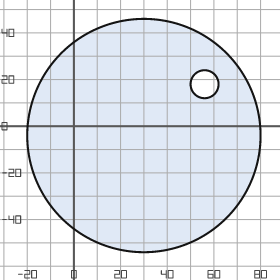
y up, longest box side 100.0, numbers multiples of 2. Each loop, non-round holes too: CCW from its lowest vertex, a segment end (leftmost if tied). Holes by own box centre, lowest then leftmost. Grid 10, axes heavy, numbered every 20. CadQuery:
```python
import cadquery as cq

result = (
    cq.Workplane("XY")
    .moveTo(30.0, -4.0)
    .circle(50.0)
    .moveTo(56.0, 18.0)
    .circle(6.0)
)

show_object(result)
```